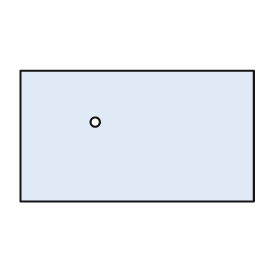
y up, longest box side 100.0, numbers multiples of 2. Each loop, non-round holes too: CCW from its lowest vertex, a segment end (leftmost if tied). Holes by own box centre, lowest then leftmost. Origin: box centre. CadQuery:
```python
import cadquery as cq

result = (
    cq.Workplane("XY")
    .moveTo(-50.0, -28.0)
    .lineTo(50.0, -28.0)
    .lineTo(50.0, 28.0)
    .lineTo(-50.0, 28.0)
    .close()
    .moveTo(-18.0, 6.0)
    .circle(2.0)
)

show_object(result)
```